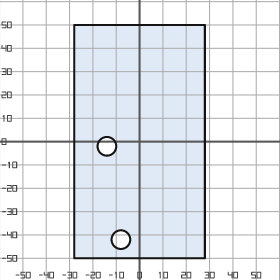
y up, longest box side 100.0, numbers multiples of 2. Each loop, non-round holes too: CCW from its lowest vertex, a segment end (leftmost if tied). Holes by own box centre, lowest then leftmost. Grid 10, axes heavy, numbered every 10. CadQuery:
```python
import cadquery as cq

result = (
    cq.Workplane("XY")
    .moveTo(-28.0, -50.0)
    .lineTo(28.0, -50.0)
    .lineTo(28.0, 50.0)
    .lineTo(-28.0, 50.0)
    .close()
    .moveTo(-8.0, -42.0)
    .circle(4.0)
    .moveTo(-14.0, -2.0)
    .circle(4.0)
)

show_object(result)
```